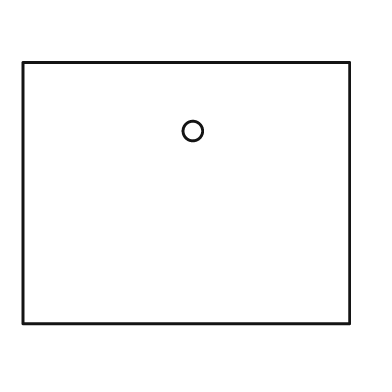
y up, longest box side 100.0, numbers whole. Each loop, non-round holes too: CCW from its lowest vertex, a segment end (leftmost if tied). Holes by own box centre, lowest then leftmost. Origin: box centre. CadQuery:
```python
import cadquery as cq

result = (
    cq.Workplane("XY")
    .moveTo(-50.0, -40.0)
    .lineTo(50.0, -40.0)
    .lineTo(50.0, 40.0)
    .lineTo(-50.0, 40.0)
    .close()
    .moveTo(2.0, 19.0)
    .circle(3.0)
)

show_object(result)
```